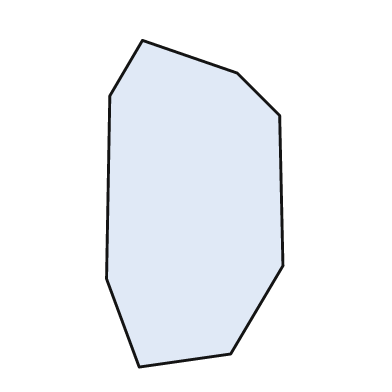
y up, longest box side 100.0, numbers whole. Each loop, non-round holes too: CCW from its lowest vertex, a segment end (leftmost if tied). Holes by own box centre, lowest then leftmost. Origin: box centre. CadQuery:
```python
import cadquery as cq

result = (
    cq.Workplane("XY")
    .moveTo(-17.0, -50.0)
    .lineTo(11.0, -46.0)
    .lineTo(27.0, -19.0)
    .lineTo(26.0, 27.0)
    .lineTo(13.0, 40.0)
    .lineTo(-16.0, 50.0)
    .lineTo(-26.0, 33.0)
    .lineTo(-27.0, -23.0)
    .close()
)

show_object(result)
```